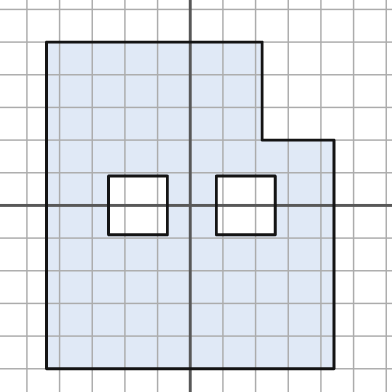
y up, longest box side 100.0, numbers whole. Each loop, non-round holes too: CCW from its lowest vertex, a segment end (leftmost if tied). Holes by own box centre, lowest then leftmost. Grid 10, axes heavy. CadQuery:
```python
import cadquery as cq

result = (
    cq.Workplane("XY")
    .moveTo(-44.0, -50.0)
    .lineTo(44.0, -50.0)
    .lineTo(44.0, 20.0)
    .lineTo(22.0, 20.0)
    .lineTo(22.0, 50.0)
    .lineTo(-44.0, 50.0)
    .close()
    .moveTo(-25.0, -9.0)
    .lineTo(-7.0, -9.0)
    .lineTo(-7.0, 9.0)
    .lineTo(-25.0, 9.0)
    .close()
    .moveTo(8.0, -9.0)
    .lineTo(26.0, -9.0)
    .lineTo(26.0, 9.0)
    .lineTo(8.0, 9.0)
    .close()
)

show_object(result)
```